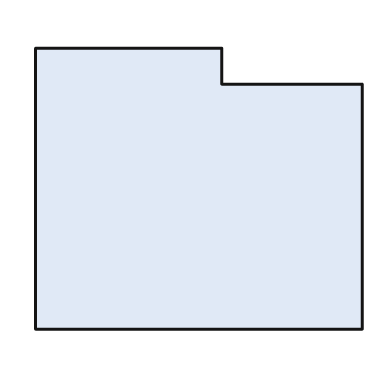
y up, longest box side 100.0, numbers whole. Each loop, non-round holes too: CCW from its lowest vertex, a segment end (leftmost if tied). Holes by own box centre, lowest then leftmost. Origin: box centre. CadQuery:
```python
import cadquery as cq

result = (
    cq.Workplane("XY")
    .moveTo(-50.0, -43.0)
    .lineTo(50.0, -43.0)
    .lineTo(50.0, 32.0)
    .lineTo(7.0, 32.0)
    .lineTo(7.0, 43.0)
    .lineTo(-50.0, 43.0)
    .close()
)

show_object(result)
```